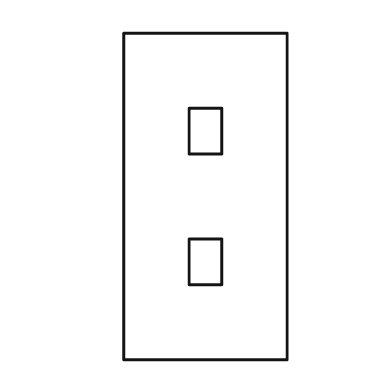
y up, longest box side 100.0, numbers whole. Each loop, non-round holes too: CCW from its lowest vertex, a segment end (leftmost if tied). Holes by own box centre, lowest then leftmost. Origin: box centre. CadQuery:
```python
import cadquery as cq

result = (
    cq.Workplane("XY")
    .moveTo(-25.0, -50.0)
    .lineTo(25.0, -50.0)
    .lineTo(25.0, 50.0)
    .lineTo(-25.0, 50.0)
    .close()
    .moveTo(-5.0, -27.0)
    .lineTo(5.0, -27.0)
    .lineTo(5.0, -13.0)
    .lineTo(-5.0, -13.0)
    .close()
    .moveTo(-5.0, 13.0)
    .lineTo(5.0, 13.0)
    .lineTo(5.0, 27.0)
    .lineTo(-5.0, 27.0)
    .close()
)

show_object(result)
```